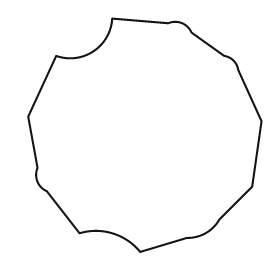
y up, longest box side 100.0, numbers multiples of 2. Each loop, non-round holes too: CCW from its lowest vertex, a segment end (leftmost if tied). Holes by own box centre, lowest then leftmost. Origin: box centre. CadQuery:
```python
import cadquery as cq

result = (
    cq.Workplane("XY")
    .moveTo(-2.0, -50.0)
    .lineTo(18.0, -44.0)
    .threePointArc((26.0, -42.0), (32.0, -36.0))
    .lineTo(46.0, -22.0)
    .lineTo(50.0, 6.0)
    .lineTo(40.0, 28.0)
    .threePointArc((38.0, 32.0), (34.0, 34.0))
    .lineTo(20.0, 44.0)
    .threePointArc((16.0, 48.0), (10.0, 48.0))
    .lineTo(-14.0, 50.0)
    .threePointArc((-22.0, 36.0), (-38.0, 34.0))
    .lineTo(-50.0, 8.0)
    .lineTo(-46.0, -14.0)
    .threePointArc((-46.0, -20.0), (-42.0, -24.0))
    .lineTo(-28.0, -42.0)
    .threePointArc((-14.0, -42.0), (-2.0, -50.0))
    .close()
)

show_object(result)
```